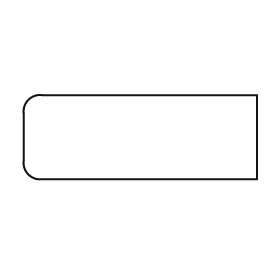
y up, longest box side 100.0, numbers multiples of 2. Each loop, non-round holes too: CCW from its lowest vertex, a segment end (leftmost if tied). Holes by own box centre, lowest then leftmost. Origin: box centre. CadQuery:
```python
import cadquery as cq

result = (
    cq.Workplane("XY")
    .moveTo(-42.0, -18.0)
    .lineTo(50.0, -18.0)
    .lineTo(50.0, 18.0)
    .lineTo(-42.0, 18.0)
    .threePointArc((-48.0, 16.0), (-50.0, 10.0))
    .lineTo(-50.0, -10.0)
    .threePointArc((-48.0, -16.0), (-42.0, -18.0))
    .close()
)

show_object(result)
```